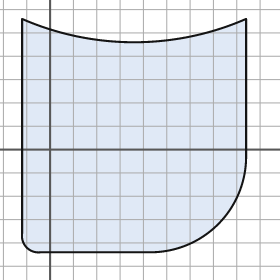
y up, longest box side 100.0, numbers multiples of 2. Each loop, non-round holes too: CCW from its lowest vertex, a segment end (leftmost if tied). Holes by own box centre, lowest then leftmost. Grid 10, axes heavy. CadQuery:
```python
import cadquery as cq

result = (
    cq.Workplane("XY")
    .moveTo(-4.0, -44.0)
    .lineTo(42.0, -44.0)
    .threePointArc((72.0, -32.0), (84.0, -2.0))
    .lineTo(84.0, 56.0)
    .threePointArc((36.0, 46.0), (-12.0, 56.0))
    .lineTo(-12.0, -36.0)
    .threePointArc((-10.0, -42.0), (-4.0, -44.0))
    .close()
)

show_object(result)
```